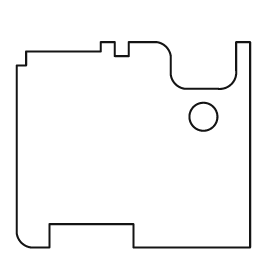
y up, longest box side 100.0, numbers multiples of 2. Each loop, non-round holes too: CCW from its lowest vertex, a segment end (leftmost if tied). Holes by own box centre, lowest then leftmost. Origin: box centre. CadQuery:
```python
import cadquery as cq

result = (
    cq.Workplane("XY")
    .moveTo(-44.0, -44.0)
    .lineTo(-36.0, -44.0)
    .lineTo(-36.0, -34.0)
    .lineTo(0.0, -34.0)
    .lineTo(0.0, -44.0)
    .lineTo(50.0, -44.0)
    .lineTo(50.0, 44.0)
    .lineTo(44.0, 44.0)
    .lineTo(44.0, 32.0)
    .threePointArc((42.0, 26.0), (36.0, 24.0))
    .lineTo(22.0, 24.0)
    .threePointArc((18.0, 26.0), (16.0, 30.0))
    .lineTo(16.0, 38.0)
    .threePointArc((14.0, 42.0), (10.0, 44.0))
    .lineTo(-2.0, 44.0)
    .lineTo(-2.0, 38.0)
    .lineTo(-8.0, 38.0)
    .lineTo(-8.0, 44.0)
    .lineTo(-14.0, 44.0)
    .lineTo(-14.0, 40.0)
    .lineTo(-46.0, 40.0)
    .lineTo(-46.0, 34.0)
    .lineTo(-50.0, 34.0)
    .lineTo(-50.0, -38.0)
    .threePointArc((-48.0, -42.0), (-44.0, -44.0))
    .close()
    .moveTo(30.0, 12.0)
    .circle(6.0)
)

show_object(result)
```